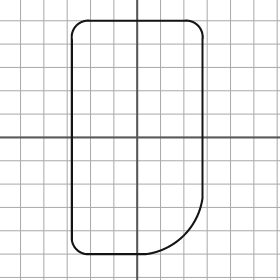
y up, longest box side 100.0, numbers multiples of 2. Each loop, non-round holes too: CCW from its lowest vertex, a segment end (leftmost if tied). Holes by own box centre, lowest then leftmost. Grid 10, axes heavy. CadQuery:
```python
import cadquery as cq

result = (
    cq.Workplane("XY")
    .moveTo(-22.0, -50.0)
    .lineTo(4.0, -50.0)
    .threePointArc((20.0, -42.0), (28.0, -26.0))
    .lineTo(28.0, 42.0)
    .threePointArc((26.0, 48.0), (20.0, 50.0))
    .lineTo(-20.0, 50.0)
    .threePointArc((-26.0, 48.0), (-28.0, 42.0))
    .lineTo(-28.0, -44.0)
    .threePointArc((-26.0, -48.0), (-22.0, -50.0))
    .close()
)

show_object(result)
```